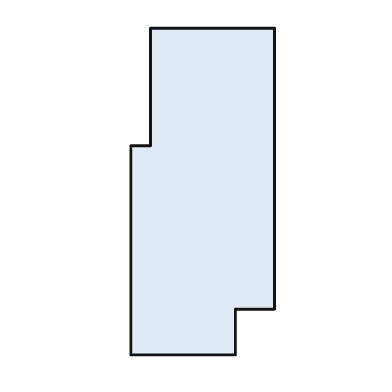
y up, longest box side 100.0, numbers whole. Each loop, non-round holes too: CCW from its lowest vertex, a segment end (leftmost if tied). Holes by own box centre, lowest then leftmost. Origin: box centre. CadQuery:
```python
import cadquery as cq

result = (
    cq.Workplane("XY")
    .moveTo(-22.0, -50.0)
    .lineTo(10.0, -50.0)
    .lineTo(10.0, -36.0)
    .lineTo(22.0, -36.0)
    .lineTo(22.0, 50.0)
    .lineTo(-16.0, 50.0)
    .lineTo(-16.0, 14.0)
    .lineTo(-22.0, 14.0)
    .close()
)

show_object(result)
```